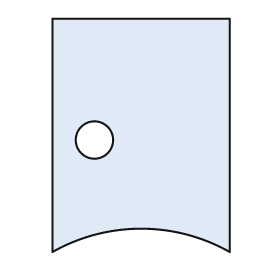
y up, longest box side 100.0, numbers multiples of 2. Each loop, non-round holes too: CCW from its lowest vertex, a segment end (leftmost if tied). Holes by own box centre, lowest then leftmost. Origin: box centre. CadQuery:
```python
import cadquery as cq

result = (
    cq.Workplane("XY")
    .moveTo(-38.0, -50.0)
    .threePointArc((0.0, -40.0), (38.0, -50.0))
    .lineTo(38.0, 50.0)
    .lineTo(-38.0, 50.0)
    .close()
    .moveTo(-20.0, -2.0)
    .circle(8.0)
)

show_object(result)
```